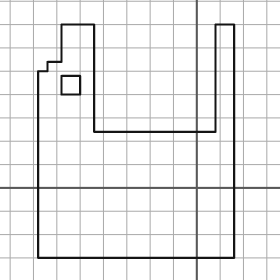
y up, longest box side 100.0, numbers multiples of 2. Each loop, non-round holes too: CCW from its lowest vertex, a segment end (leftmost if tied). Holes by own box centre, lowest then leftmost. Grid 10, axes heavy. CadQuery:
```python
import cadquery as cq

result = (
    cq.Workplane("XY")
    .moveTo(-68.0, -30.0)
    .lineTo(16.0, -30.0)
    .lineTo(16.0, 70.0)
    .lineTo(8.0, 70.0)
    .lineTo(8.0, 24.0)
    .lineTo(-44.0, 24.0)
    .lineTo(-44.0, 70.0)
    .lineTo(-58.0, 70.0)
    .lineTo(-58.0, 54.0)
    .lineTo(-64.0, 54.0)
    .lineTo(-64.0, 50.0)
    .lineTo(-68.0, 50.0)
    .close()
    .moveTo(-58.0, 40.0)
    .lineTo(-50.0, 40.0)
    .lineTo(-50.0, 48.0)
    .lineTo(-58.0, 48.0)
    .close()
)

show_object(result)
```